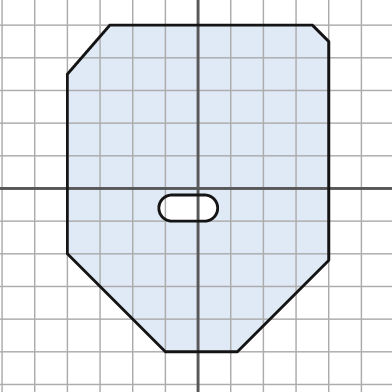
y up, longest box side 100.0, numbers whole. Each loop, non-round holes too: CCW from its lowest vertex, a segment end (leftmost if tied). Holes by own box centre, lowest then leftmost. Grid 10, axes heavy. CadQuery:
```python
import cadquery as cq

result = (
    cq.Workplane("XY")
    .moveTo(-10.0, -50.0)
    .lineTo(12.0, -50.0)
    .lineTo(40.0, -22.0)
    .lineTo(40.0, 45.0)
    .lineTo(35.0, 50.0)
    .lineTo(-27.0, 50.0)
    .lineTo(-40.0, 35.0)
    .lineTo(-40.0, -20.0)
    .close()
    .moveTo(-8.0, -10.0)
    .lineTo(2.0, -10.0)
    .threePointArc((6.0, -6.0), (2.0, -2.0))
    .lineTo(-8.0, -2.0)
    .threePointArc((-12.0, -6.0), (-8.0, -10.0))
    .close()
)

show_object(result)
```